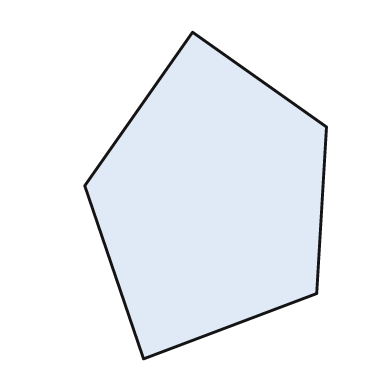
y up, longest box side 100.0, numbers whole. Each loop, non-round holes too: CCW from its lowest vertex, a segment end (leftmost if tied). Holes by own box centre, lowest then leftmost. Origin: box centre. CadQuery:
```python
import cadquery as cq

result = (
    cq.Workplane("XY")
    .moveTo(-19.0, -50.0)
    .lineTo(34.0, -30.0)
    .lineTo(37.0, 21.0)
    .lineTo(-4.0, 50.0)
    .lineTo(-37.0, 3.0)
    .close()
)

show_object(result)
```